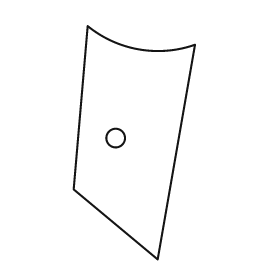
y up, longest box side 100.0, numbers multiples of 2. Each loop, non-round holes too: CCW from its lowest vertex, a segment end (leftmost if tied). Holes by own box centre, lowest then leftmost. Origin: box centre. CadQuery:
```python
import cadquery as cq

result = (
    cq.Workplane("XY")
    .moveTo(10.0, -50.0)
    .lineTo(26.0, 42.0)
    .threePointArc((2.0, 40.0), (-20.0, 50.0))
    .lineTo(-26.0, -20.0)
    .close()
    .moveTo(-8.0, 2.0)
    .circle(4.0)
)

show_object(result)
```